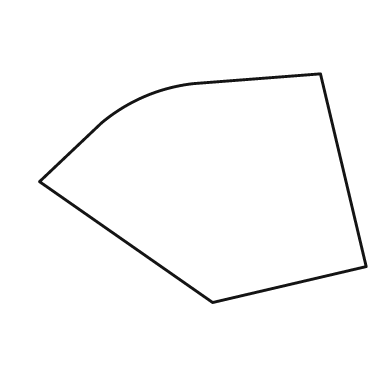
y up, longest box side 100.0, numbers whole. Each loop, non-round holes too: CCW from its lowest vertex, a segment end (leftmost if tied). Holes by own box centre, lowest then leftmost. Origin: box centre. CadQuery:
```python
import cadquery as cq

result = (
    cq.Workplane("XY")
    .moveTo(3.0, -35.0)
    .lineTo(50.0, -24.0)
    .lineTo(36.0, 35.0)
    .lineTo(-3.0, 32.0)
    .threePointArc((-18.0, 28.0), (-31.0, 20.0))
    .lineTo(-50.0, 2.0)
    .close()
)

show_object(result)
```